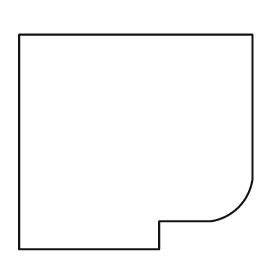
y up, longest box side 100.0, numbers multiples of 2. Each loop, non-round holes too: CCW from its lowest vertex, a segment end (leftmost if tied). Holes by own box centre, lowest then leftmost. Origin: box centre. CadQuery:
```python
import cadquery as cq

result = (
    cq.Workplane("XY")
    .moveTo(-50.0, -46.0)
    .lineTo(10.0, -46.0)
    .lineTo(10.0, -34.0)
    .lineTo(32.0, -34.0)
    .threePointArc((44.0, -28.0), (50.0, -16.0))
    .lineTo(50.0, 46.0)
    .lineTo(-50.0, 46.0)
    .close()
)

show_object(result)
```